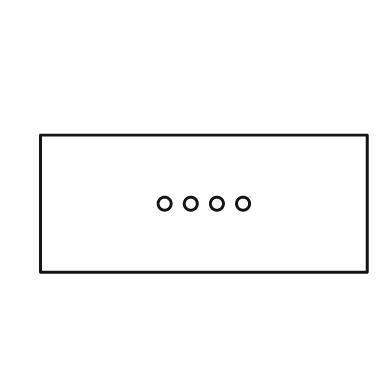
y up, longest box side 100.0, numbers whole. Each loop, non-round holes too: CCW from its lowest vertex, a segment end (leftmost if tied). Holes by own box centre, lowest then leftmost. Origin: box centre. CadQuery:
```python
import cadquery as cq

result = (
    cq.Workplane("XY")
    .moveTo(-50.0, -21.0)
    .lineTo(50.0, -21.0)
    .lineTo(50.0, 21.0)
    .lineTo(-50.0, 21.0)
    .close()
    .moveTo(-12.0, 0.0)
    .circle(2.0)
    .moveTo(-4.0, 0.0)
    .circle(2.0)
    .moveTo(4.0, 0.0)
    .circle(2.0)
    .moveTo(12.0, 0.0)
    .circle(2.0)
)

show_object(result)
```